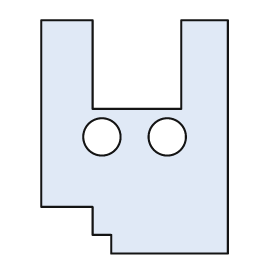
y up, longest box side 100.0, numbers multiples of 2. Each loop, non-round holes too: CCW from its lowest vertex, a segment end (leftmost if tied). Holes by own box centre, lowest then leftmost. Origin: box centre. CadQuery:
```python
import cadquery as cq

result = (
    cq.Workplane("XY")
    .moveTo(-10.0, -50.0)
    .lineTo(40.0, -50.0)
    .lineTo(40.0, 50.0)
    .lineTo(20.0, 50.0)
    .lineTo(20.0, 12.0)
    .lineTo(-18.0, 12.0)
    .lineTo(-18.0, 50.0)
    .lineTo(-40.0, 50.0)
    .lineTo(-40.0, -30.0)
    .lineTo(-18.0, -30.0)
    .lineTo(-18.0, -42.0)
    .lineTo(-10.0, -42.0)
    .close()
    .moveTo(-14.0, 0.0)
    .circle(8.0)
    .moveTo(14.0, 0.0)
    .circle(8.0)
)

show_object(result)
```